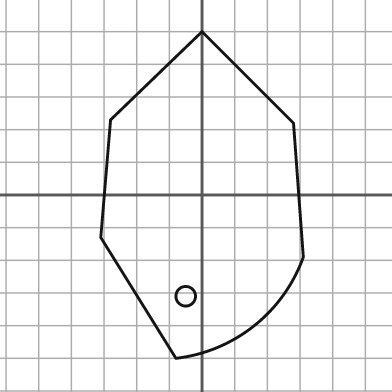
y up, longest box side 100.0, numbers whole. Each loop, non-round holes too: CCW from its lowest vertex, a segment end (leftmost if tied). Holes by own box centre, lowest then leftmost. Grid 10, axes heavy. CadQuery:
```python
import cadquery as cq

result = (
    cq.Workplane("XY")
    .moveTo(-8.0, -50.0)
    .threePointArc((16.0, -40.0), (31.0, -19.0))
    .lineTo(28.0, 22.0)
    .lineTo(0.0, 50.0)
    .lineTo(-28.0, 23.0)
    .lineTo(-31.0, -13.0)
    .close()
    .moveTo(-5.0, -31.0)
    .circle(3.0)
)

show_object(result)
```